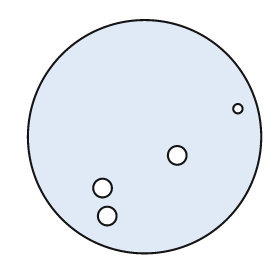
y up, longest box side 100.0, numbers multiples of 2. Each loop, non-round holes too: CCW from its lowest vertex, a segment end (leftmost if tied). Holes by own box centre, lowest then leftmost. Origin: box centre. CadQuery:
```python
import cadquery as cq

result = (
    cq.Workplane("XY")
    .moveTo(0.0, 0.0)
    .circle(50.0)
    .moveTo(-16.0, -34.0)
    .circle(4.0)
    .moveTo(-18.0, -22.0)
    .circle(4.0)
    .moveTo(14.0, -8.0)
    .circle(4.0)
    .moveTo(40.0, 12.0)
    .circle(2.0)
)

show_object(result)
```